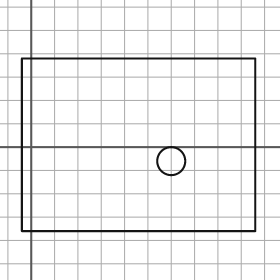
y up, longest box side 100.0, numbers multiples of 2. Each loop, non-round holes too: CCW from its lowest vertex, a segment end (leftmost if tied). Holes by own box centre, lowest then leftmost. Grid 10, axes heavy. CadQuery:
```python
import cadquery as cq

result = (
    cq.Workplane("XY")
    .moveTo(-4.0, -36.0)
    .lineTo(96.0, -36.0)
    .lineTo(96.0, 38.0)
    .lineTo(-4.0, 38.0)
    .close()
    .moveTo(60.0, -6.0)
    .circle(6.0)
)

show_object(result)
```